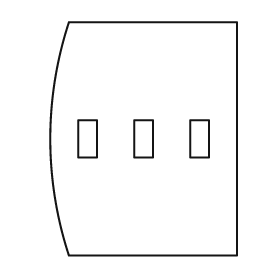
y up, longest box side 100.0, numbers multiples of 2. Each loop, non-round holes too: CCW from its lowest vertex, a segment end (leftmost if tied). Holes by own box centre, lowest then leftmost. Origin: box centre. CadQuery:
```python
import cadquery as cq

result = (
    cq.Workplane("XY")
    .moveTo(-32.0, -50.0)
    .lineTo(40.0, -50.0)
    .lineTo(40.0, 50.0)
    .lineTo(-32.0, 50.0)
    .threePointArc((-40.0, 0.0), (-32.0, -50.0))
    .close()
    .moveTo(-28.0, -8.0)
    .lineTo(-20.0, -8.0)
    .lineTo(-20.0, 8.0)
    .lineTo(-28.0, 8.0)
    .close()
    .moveTo(-4.0, -8.0)
    .lineTo(4.0, -8.0)
    .lineTo(4.0, 8.0)
    .lineTo(-4.0, 8.0)
    .close()
    .moveTo(20.0, -8.0)
    .lineTo(28.0, -8.0)
    .lineTo(28.0, 8.0)
    .lineTo(20.0, 8.0)
    .close()
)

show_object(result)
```